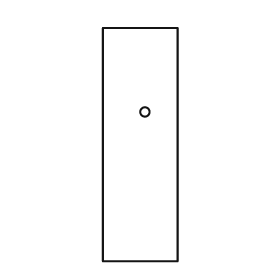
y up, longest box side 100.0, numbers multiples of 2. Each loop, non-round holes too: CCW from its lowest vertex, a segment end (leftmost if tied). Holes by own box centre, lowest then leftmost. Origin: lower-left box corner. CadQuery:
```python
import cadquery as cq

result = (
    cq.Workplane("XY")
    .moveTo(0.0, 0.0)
    .lineTo(32.0, 0.0)
    .lineTo(32.0, 100.0)
    .lineTo(0.0, 100.0)
    .close()
    .moveTo(18.0, 64.0)
    .circle(2.0)
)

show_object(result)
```